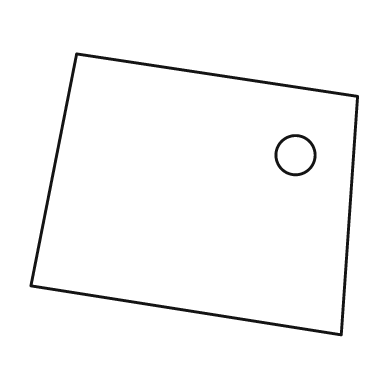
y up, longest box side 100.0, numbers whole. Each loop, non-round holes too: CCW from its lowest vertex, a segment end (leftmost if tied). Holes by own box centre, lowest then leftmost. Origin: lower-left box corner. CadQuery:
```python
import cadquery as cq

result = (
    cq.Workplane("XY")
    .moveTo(95.0, 0.0)
    .lineTo(100.0, 73.0)
    .lineTo(14.0, 86.0)
    .lineTo(0.0, 15.0)
    .close()
    .moveTo(81.0, 55.0)
    .circle(6.0)
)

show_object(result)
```